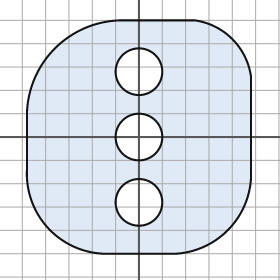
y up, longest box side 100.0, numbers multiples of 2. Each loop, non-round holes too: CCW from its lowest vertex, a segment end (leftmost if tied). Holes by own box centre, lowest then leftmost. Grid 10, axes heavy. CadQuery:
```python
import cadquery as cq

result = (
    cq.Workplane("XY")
    .moveTo(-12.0, -50.0)
    .lineTo(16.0, -50.0)
    .threePointArc((38.0, -40.0), (48.0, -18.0))
    .lineTo(48.0, 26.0)
    .threePointArc((40.0, 42.0), (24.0, 50.0))
    .lineTo(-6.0, 50.0)
    .threePointArc((-36.0, 38.0), (-48.0, 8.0))
    .lineTo(-48.0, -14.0)
    .threePointArc((-38.0, -40.0), (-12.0, -50.0))
    .close()
    .moveTo(0.0, -28.0)
    .circle(10.0)
    .moveTo(0.0, 0.0)
    .circle(10.0)
    .moveTo(0.0, 28.0)
    .circle(10.0)
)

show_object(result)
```